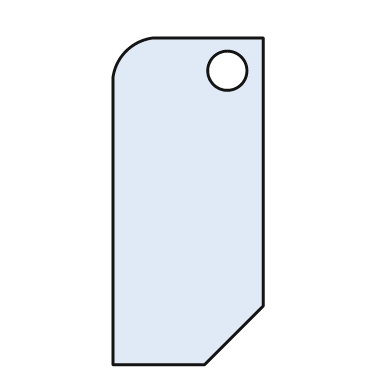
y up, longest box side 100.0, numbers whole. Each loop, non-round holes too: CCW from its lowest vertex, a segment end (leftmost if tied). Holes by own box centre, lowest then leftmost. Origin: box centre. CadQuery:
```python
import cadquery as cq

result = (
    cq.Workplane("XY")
    .moveTo(-23.0, -50.0)
    .lineTo(5.0, -50.0)
    .lineTo(23.0, -32.0)
    .lineTo(23.0, 50.0)
    .lineTo(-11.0, 50.0)
    .threePointArc((-19.0, 46.0), (-23.0, 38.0))
    .close()
    .moveTo(12.0, 40.0)
    .circle(6.0)
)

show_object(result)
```